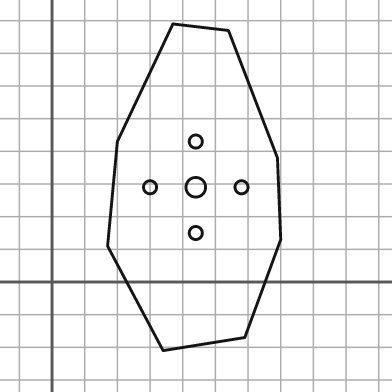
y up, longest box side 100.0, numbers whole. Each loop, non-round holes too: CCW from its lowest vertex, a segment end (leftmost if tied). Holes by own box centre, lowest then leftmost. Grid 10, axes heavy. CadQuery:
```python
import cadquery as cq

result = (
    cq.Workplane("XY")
    .moveTo(34.0, -21.0)
    .lineTo(59.0, -17.0)
    .lineTo(70.0, 13.0)
    .lineTo(69.0, 38.0)
    .lineTo(54.0, 77.0)
    .lineTo(37.0, 79.0)
    .lineTo(20.0, 43.0)
    .lineTo(17.0, 11.0)
    .close()
    .moveTo(44.0, 15.0)
    .circle(2.0)
    .moveTo(30.0, 29.0)
    .circle(2.0)
    .moveTo(44.0, 29.0)
    .circle(3.0)
    .moveTo(58.0, 29.0)
    .circle(2.0)
    .moveTo(44.0, 43.0)
    .circle(2.0)
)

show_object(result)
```